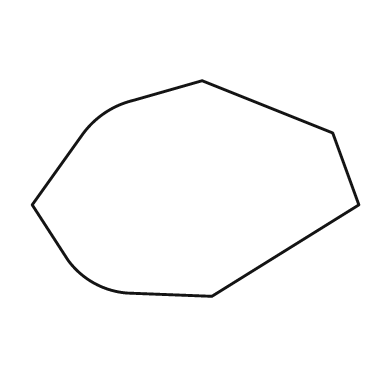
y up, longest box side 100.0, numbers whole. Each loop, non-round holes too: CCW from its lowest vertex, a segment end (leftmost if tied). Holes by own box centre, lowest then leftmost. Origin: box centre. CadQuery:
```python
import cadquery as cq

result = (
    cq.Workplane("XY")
    .moveTo(5.0, -33.0)
    .lineTo(50.0, -5.0)
    .lineTo(42.0, 17.0)
    .lineTo(2.0, 33.0)
    .lineTo(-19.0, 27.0)
    .threePointArc((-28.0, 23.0), (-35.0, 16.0))
    .lineTo(-50.0, -5.0)
    .lineTo(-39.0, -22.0)
    .threePointArc((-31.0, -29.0), (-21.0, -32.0))
    .close()
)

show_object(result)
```